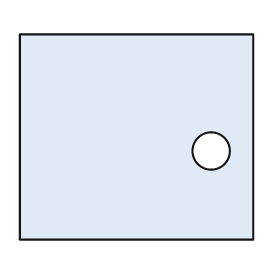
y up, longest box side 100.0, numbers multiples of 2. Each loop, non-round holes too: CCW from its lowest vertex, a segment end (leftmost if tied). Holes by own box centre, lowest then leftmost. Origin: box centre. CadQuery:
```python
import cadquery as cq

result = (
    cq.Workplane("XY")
    .moveTo(-50.0, -44.0)
    .lineTo(50.0, -44.0)
    .lineTo(50.0, 44.0)
    .lineTo(-50.0, 44.0)
    .close()
    .moveTo(32.0, -6.0)
    .circle(8.0)
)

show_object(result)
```